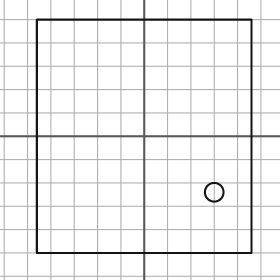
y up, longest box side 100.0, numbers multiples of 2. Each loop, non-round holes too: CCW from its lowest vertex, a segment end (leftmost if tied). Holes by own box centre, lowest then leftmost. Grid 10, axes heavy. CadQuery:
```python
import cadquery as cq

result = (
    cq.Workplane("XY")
    .moveTo(-46.0, -50.0)
    .lineTo(46.0, -50.0)
    .lineTo(46.0, 50.0)
    .lineTo(-46.0, 50.0)
    .close()
    .moveTo(30.0, -24.0)
    .circle(4.0)
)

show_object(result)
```